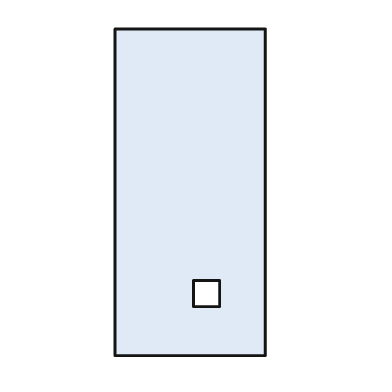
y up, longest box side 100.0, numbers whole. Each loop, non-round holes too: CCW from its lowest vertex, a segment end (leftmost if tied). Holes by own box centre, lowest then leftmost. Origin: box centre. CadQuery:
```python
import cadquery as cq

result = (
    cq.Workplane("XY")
    .moveTo(-23.0, -50.0)
    .lineTo(23.0, -50.0)
    .lineTo(23.0, 50.0)
    .lineTo(-23.0, 50.0)
    .close()
    .moveTo(1.0, -35.0)
    .lineTo(9.0, -35.0)
    .lineTo(9.0, -27.0)
    .lineTo(1.0, -27.0)
    .close()
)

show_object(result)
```